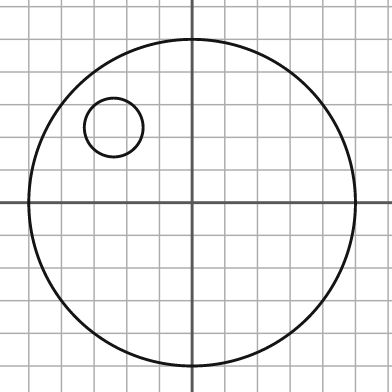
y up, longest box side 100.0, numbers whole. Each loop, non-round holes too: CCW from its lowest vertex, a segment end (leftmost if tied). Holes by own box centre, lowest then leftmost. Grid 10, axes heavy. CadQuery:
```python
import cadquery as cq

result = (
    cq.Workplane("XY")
    .moveTo(0.0, 0.0)
    .circle(50.0)
    .moveTo(-24.0, 23.0)
    .circle(9.0)
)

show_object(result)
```